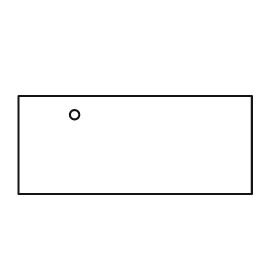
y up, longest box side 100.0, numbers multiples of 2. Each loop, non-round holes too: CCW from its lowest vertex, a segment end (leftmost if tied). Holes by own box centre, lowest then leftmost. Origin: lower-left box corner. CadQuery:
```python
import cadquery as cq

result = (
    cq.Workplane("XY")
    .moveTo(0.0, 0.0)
    .lineTo(100.0, 0.0)
    .lineTo(100.0, 42.0)
    .lineTo(0.0, 42.0)
    .close()
    .moveTo(24.0, 34.0)
    .circle(2.0)
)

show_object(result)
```